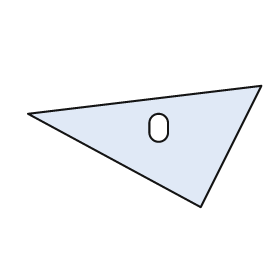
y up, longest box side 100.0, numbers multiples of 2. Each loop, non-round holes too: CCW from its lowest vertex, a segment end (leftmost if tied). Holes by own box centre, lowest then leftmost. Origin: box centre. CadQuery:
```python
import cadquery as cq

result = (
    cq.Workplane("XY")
    .moveTo(24.0, -26.0)
    .lineTo(50.0, 26.0)
    .lineTo(-50.0, 14.0)
    .close()
    .moveTo(2.0, 6.0)
    .threePointArc((6.0, 2.0), (10.0, 6.0))
    .lineTo(10.0, 10.0)
    .threePointArc((6.0, 14.0), (2.0, 10.0))
    .close()
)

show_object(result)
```